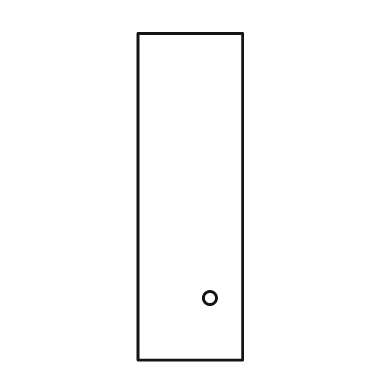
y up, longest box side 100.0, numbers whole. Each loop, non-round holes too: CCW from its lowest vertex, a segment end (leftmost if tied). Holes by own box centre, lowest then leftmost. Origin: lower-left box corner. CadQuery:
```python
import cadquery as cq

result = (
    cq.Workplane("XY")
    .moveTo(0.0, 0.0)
    .lineTo(32.0, 0.0)
    .lineTo(32.0, 100.0)
    .lineTo(0.0, 100.0)
    .close()
    .moveTo(22.0, 19.0)
    .circle(2.0)
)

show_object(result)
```